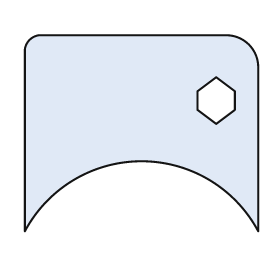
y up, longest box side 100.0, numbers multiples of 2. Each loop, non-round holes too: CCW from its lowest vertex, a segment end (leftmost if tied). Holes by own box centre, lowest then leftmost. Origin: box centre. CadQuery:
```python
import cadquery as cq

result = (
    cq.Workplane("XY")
    .moveTo(-50.0, -42.0)
    .threePointArc((0.0, -12.0), (50.0, -42.0))
    .lineTo(50.0, 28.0)
    .threePointArc((46.0, 38.0), (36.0, 42.0))
    .lineTo(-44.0, 42.0)
    .threePointArc((-48.0, 40.0), (-50.0, 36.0))
    .close()
    .moveTo(32.0, 4.0)
    .lineTo(40.0, 10.0)
    .lineTo(40.0, 18.0)
    .lineTo(32.0, 24.0)
    .lineTo(24.0, 18.0)
    .lineTo(24.0, 10.0)
    .close()
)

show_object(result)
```